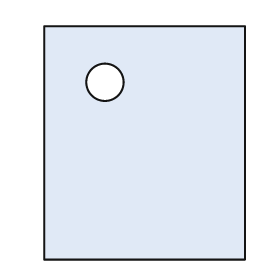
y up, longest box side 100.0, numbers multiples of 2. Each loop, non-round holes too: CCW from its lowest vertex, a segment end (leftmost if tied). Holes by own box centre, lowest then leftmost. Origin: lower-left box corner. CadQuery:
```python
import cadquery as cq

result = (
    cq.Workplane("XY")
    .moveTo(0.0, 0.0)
    .lineTo(86.0, 0.0)
    .lineTo(86.0, 100.0)
    .lineTo(0.0, 100.0)
    .close()
    .moveTo(26.0, 76.0)
    .circle(8.0)
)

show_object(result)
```